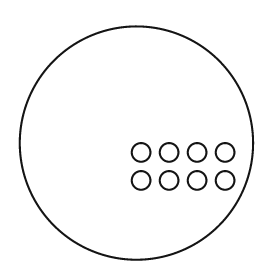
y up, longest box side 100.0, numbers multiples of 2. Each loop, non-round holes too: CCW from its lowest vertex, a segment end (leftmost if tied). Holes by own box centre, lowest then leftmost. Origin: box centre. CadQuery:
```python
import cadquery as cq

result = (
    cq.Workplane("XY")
    .moveTo(0.0, 0.0)
    .circle(50.0)
    .moveTo(2.0, -16.0)
    .circle(4.0)
    .moveTo(14.0, -16.0)
    .circle(4.0)
    .moveTo(26.0, -16.0)
    .circle(4.0)
    .moveTo(38.0, -16.0)
    .circle(4.0)
    .moveTo(2.0, -4.0)
    .circle(4.0)
    .moveTo(14.0, -4.0)
    .circle(4.0)
    .moveTo(26.0, -4.0)
    .circle(4.0)
    .moveTo(38.0, -4.0)
    .circle(4.0)
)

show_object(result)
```